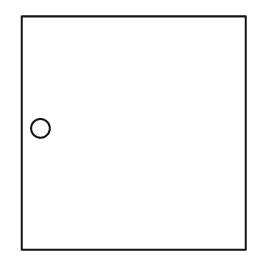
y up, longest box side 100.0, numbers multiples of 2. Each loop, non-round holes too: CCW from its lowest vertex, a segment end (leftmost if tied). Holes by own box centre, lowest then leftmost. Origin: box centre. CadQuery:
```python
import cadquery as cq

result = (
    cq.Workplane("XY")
    .moveTo(-48.0, -50.0)
    .lineTo(48.0, -50.0)
    .lineTo(48.0, 50.0)
    .lineTo(-48.0, 50.0)
    .close()
    .moveTo(-40.0, 2.0)
    .circle(4.0)
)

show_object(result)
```